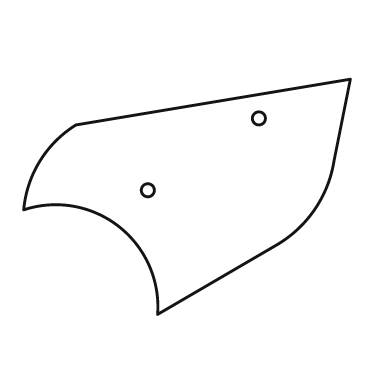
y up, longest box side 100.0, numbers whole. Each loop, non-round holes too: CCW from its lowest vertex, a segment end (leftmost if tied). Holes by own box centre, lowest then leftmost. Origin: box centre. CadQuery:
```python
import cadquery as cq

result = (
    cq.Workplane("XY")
    .moveTo(-9.0, -36.0)
    .lineTo(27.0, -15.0)
    .threePointArc((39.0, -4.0), (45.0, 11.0))
    .lineTo(50.0, 36.0)
    .lineTo(-34.0, 22.0)
    .threePointArc((-45.0, 11.0), (-50.0, -4.0))
    .threePointArc((-21.0, -9.0), (-9.0, -36.0))
    .close()
    .moveTo(-12.0, 2.0)
    .circle(2.0)
    .moveTo(22.0, 24.0)
    .circle(2.0)
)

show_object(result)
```